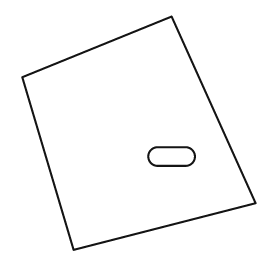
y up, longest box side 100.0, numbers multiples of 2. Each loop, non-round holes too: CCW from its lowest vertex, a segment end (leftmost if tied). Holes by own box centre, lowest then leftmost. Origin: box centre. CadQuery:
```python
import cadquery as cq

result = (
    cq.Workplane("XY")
    .moveTo(-28.0, -50.0)
    .lineTo(50.0, -30.0)
    .lineTo(14.0, 50.0)
    .lineTo(-50.0, 24.0)
    .close()
    .moveTo(8.0, -14.0)
    .lineTo(20.0, -14.0)
    .threePointArc((24.0, -10.0), (20.0, -6.0))
    .lineTo(8.0, -6.0)
    .threePointArc((4.0, -10.0), (8.0, -14.0))
    .close()
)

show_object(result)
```